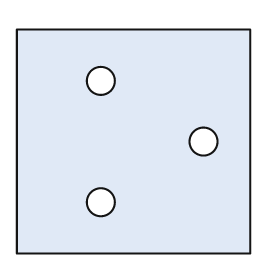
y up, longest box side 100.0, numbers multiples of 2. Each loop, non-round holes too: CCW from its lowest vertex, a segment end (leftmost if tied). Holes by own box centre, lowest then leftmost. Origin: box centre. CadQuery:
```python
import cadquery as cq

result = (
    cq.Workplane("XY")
    .moveTo(-50.0, -48.0)
    .lineTo(50.0, -48.0)
    .lineTo(50.0, 48.0)
    .lineTo(-50.0, 48.0)
    .close()
    .moveTo(-14.0, -26.0)
    .circle(6.0)
    .moveTo(30.0, 0.0)
    .circle(6.0)
    .moveTo(-14.0, 26.0)
    .circle(6.0)
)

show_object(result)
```